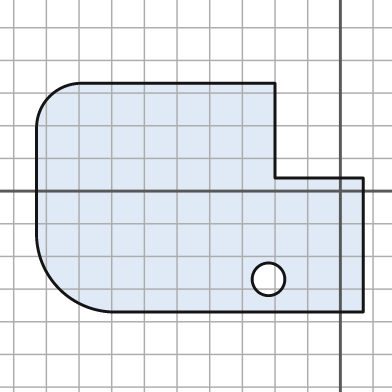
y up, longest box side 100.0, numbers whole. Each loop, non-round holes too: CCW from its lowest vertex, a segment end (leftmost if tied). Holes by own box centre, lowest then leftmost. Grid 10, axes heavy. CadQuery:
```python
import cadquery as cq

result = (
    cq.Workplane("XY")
    .moveTo(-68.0, -37.0)
    .lineTo(7.0, -37.0)
    .lineTo(7.0, 4.0)
    .lineTo(-20.0, 4.0)
    .lineTo(-20.0, 33.0)
    .lineTo(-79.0, 33.0)
    .threePointArc((-89.0, 29.0), (-93.0, 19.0))
    .lineTo(-93.0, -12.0)
    .threePointArc((-86.0, -30.0), (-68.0, -37.0))
    .close()
    .moveTo(-22.0, -27.0)
    .circle(5.0)
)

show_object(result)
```